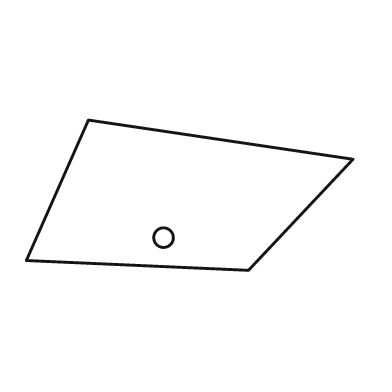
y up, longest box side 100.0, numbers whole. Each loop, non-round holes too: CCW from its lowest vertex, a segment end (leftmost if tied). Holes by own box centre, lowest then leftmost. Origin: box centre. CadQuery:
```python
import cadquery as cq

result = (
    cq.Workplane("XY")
    .moveTo(18.0, -23.0)
    .lineTo(50.0, 11.0)
    .lineTo(-31.0, 23.0)
    .lineTo(-50.0, -20.0)
    .close()
    .moveTo(-8.0, -13.0)
    .circle(3.0)
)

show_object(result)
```